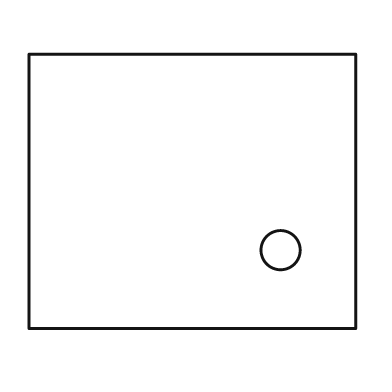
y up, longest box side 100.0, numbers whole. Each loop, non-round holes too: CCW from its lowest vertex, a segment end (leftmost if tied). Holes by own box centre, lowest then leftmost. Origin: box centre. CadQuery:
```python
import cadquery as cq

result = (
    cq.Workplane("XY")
    .moveTo(-50.0, -42.0)
    .lineTo(50.0, -42.0)
    .lineTo(50.0, 42.0)
    .lineTo(-50.0, 42.0)
    .close()
    .moveTo(27.0, -18.0)
    .circle(6.0)
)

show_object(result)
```